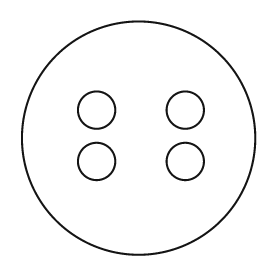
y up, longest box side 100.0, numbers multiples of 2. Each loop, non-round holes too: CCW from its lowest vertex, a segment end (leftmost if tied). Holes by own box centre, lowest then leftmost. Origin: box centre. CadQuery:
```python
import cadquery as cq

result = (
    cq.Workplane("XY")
    .moveTo(0.0, 0.0)
    .circle(50.0)
    .moveTo(-18.0, -10.0)
    .circle(8.0)
    .moveTo(20.0, -10.0)
    .circle(8.0)
    .moveTo(-18.0, 12.0)
    .circle(8.0)
    .moveTo(20.0, 12.0)
    .circle(8.0)
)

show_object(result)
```